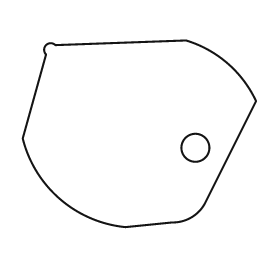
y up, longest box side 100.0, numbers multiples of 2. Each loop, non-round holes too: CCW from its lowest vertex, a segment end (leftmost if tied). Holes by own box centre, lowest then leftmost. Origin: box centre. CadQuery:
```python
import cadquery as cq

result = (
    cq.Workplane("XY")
    .moveTo(-6.0, -40.0)
    .lineTo(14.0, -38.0)
    .threePointArc((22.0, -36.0), (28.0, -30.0))
    .lineTo(50.0, 14.0)
    .threePointArc((38.0, 30.0), (20.0, 40.0))
    .lineTo(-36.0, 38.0)
    .threePointArc((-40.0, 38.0), (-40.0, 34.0))
    .lineTo(-50.0, -2.0)
    .threePointArc((-34.0, -28.0), (-6.0, -40.0))
    .close()
    .moveTo(24.0, -6.0)
    .circle(6.0)
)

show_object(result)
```